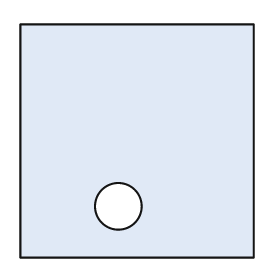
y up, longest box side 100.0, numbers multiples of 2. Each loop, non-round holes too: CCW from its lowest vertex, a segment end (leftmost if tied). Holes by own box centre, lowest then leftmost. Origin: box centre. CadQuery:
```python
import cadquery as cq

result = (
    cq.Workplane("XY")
    .moveTo(-50.0, -50.0)
    .lineTo(50.0, -50.0)
    .lineTo(50.0, 50.0)
    .lineTo(-50.0, 50.0)
    .close()
    .moveTo(-8.0, -28.0)
    .circle(10.0)
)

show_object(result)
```